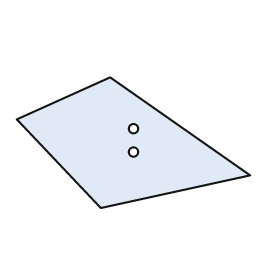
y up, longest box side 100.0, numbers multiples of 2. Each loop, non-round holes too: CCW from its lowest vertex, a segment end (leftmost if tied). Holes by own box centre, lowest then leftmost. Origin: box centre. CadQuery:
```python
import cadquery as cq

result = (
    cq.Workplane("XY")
    .moveTo(-14.0, -28.0)
    .lineTo(50.0, -14.0)
    .lineTo(-10.0, 28.0)
    .lineTo(-50.0, 10.0)
    .close()
    .moveTo(0.0, -4.0)
    .circle(2.0)
    .moveTo(0.0, 6.0)
    .circle(2.0)
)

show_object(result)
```